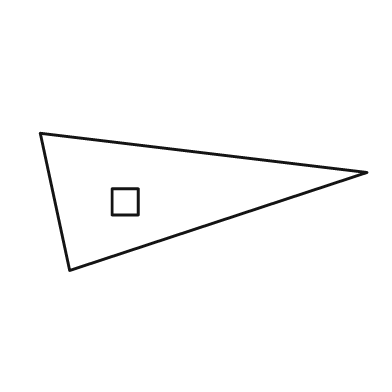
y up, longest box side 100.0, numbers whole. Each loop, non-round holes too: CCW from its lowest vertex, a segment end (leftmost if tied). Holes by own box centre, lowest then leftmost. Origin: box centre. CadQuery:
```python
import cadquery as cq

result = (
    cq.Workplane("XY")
    .moveTo(-41.0, -21.0)
    .lineTo(50.0, 9.0)
    .lineTo(-50.0, 21.0)
    .close()
    .moveTo(-28.0, -4.0)
    .lineTo(-20.0, -4.0)
    .lineTo(-20.0, 4.0)
    .lineTo(-28.0, 4.0)
    .close()
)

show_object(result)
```